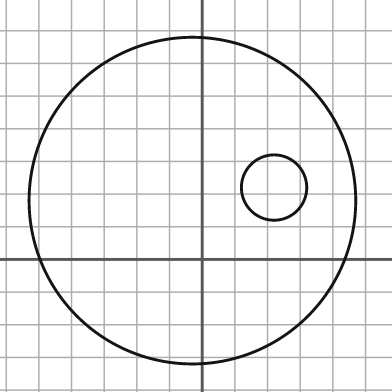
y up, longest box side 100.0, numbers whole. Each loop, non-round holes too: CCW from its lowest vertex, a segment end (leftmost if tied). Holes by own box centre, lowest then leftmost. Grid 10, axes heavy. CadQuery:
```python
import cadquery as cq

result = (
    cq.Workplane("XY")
    .moveTo(-3.0, 18.0)
    .circle(50.0)
    .moveTo(22.0, 22.0)
    .circle(10.0)
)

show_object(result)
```